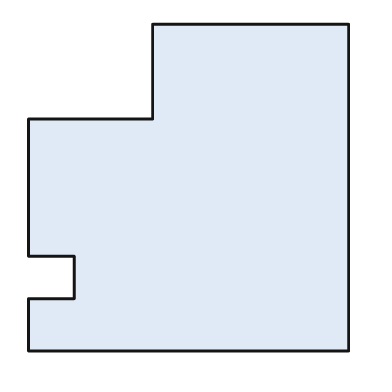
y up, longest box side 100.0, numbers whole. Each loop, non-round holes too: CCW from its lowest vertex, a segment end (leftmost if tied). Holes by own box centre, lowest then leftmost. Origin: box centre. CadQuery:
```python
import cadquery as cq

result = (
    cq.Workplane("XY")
    .moveTo(-49.0, -50.0)
    .lineTo(49.0, -50.0)
    .lineTo(49.0, 50.0)
    .lineTo(-11.0, 50.0)
    .lineTo(-11.0, 21.0)
    .lineTo(-49.0, 21.0)
    .lineTo(-49.0, -21.0)
    .lineTo(-35.0, -21.0)
    .lineTo(-35.0, -34.0)
    .lineTo(-49.0, -34.0)
    .close()
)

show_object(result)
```